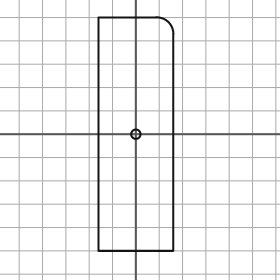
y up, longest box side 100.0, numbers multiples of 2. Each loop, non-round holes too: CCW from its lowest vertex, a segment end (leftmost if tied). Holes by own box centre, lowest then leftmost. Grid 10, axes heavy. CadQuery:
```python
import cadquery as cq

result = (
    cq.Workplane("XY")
    .moveTo(-16.0, -50.0)
    .lineTo(16.0, -50.0)
    .lineTo(16.0, 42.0)
    .threePointArc((14.0, 48.0), (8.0, 50.0))
    .lineTo(-16.0, 50.0)
    .close()
    .moveTo(0.0, 0.0)
    .circle(2.0)
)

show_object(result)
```